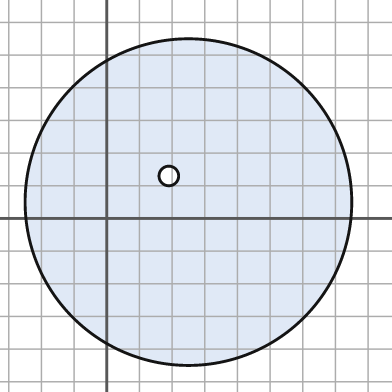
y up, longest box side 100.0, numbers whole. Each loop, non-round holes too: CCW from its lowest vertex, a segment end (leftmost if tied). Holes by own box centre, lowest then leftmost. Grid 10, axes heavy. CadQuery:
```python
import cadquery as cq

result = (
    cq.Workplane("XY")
    .moveTo(25.0, 5.0)
    .circle(50.0)
    .moveTo(19.0, 13.0)
    .circle(3.0)
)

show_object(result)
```